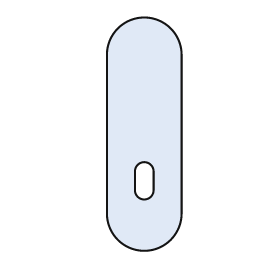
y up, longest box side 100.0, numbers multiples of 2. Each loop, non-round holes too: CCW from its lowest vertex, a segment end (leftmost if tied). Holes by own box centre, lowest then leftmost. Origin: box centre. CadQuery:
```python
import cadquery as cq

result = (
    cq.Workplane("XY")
    .moveTo(-16.0, -34.0)
    .threePointArc((0.0, -50.0), (16.0, -34.0))
    .lineTo(16.0, 34.0)
    .threePointArc((0.0, 50.0), (-16.0, 34.0))
    .close()
    .moveTo(-4.0, -24.0)
    .threePointArc((0.0, -28.0), (4.0, -24.0))
    .lineTo(4.0, -16.0)
    .threePointArc((0.0, -12.0), (-4.0, -16.0))
    .close()
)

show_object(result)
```